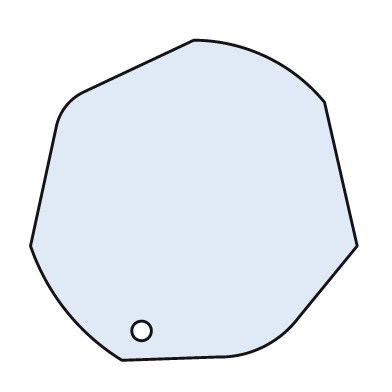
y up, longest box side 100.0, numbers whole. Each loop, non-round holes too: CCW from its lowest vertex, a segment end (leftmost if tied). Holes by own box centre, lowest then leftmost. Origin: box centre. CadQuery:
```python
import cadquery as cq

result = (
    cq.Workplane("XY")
    .moveTo(-22.0, -49.0)
    .lineTo(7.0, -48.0)
    .threePointArc((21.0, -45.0), (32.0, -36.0))
    .lineTo(50.0, -14.0)
    .lineTo(40.0, 30.0)
    .threePointArc((22.0, 44.0), (0.0, 49.0))
    .lineTo(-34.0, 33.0)
    .threePointArc((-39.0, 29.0), (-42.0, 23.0))
    .lineTo(-50.0, -14.0)
    .threePointArc((-39.0, -34.0), (-22.0, -49.0))
    .close()
    .moveTo(-16.0, -40.0)
    .circle(3.0)
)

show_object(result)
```